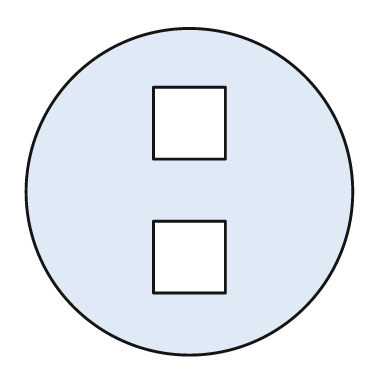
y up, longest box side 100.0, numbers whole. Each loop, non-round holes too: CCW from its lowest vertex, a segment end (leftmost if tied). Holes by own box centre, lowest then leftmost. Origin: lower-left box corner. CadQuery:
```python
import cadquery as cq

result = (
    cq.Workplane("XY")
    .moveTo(50.0, 50.0)
    .circle(50.0)
    .moveTo(39.0, 19.0)
    .lineTo(61.0, 19.0)
    .lineTo(61.0, 41.0)
    .lineTo(39.0, 41.0)
    .close()
    .moveTo(39.0, 60.0)
    .lineTo(61.0, 60.0)
    .lineTo(61.0, 82.0)
    .lineTo(39.0, 82.0)
    .close()
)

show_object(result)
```